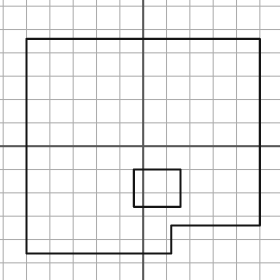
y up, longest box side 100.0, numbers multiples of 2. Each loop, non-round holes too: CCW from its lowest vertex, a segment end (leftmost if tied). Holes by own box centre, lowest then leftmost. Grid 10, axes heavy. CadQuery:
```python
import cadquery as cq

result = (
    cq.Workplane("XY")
    .moveTo(-50.0, -46.0)
    .lineTo(12.0, -46.0)
    .lineTo(12.0, -34.0)
    .lineTo(50.0, -34.0)
    .lineTo(50.0, 46.0)
    .lineTo(-50.0, 46.0)
    .close()
    .moveTo(-4.0, -26.0)
    .lineTo(16.0, -26.0)
    .lineTo(16.0, -10.0)
    .lineTo(-4.0, -10.0)
    .close()
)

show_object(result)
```